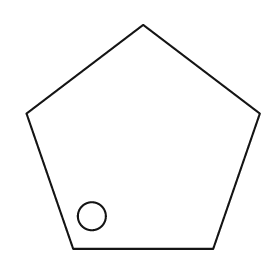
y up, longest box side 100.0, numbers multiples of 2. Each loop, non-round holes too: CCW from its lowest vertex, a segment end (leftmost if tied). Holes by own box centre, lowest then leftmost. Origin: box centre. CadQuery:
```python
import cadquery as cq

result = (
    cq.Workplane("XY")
    .moveTo(-30.0, -48.0)
    .lineTo(30.0, -48.0)
    .lineTo(50.0, 10.0)
    .lineTo(0.0, 48.0)
    .lineTo(-50.0, 10.0)
    .close()
    .moveTo(-22.0, -34.0)
    .circle(6.0)
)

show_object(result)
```